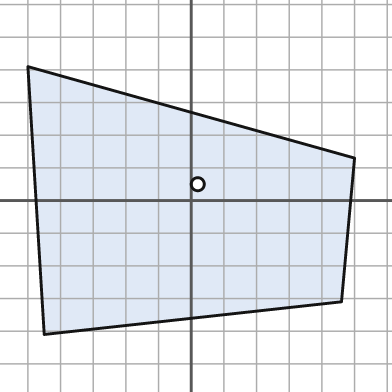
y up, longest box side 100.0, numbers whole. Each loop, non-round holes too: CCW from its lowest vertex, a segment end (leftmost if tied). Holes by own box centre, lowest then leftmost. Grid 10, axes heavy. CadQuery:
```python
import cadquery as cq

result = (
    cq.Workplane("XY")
    .moveTo(-45.0, -41.0)
    .lineTo(46.0, -31.0)
    .lineTo(50.0, 13.0)
    .lineTo(-50.0, 41.0)
    .close()
    .moveTo(2.0, 5.0)
    .circle(2.0)
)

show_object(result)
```